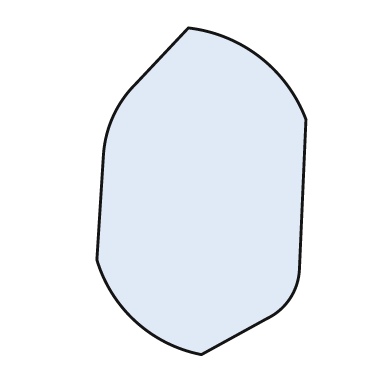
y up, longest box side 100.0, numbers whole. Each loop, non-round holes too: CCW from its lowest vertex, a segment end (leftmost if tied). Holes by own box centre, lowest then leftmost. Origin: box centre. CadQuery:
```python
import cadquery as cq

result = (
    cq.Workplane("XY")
    .moveTo(0.0, -50.0)
    .lineTo(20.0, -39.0)
    .threePointArc((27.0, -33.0), (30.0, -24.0))
    .lineTo(32.0, 22.0)
    .threePointArc((18.0, 41.0), (-4.0, 50.0))
    .lineTo(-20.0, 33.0)
    .threePointArc((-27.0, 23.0), (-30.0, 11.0))
    .lineTo(-32.0, -21.0)
    .threePointArc((-20.0, -40.0), (0.0, -50.0))
    .close()
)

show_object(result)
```